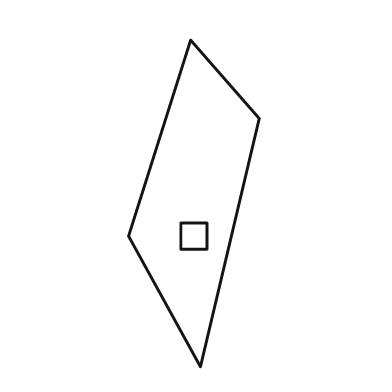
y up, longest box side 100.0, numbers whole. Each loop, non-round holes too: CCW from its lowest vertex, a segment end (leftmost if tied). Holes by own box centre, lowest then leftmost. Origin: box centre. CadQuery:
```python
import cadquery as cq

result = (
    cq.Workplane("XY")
    .moveTo(2.0, -50.0)
    .lineTo(20.0, 26.0)
    .lineTo(-1.0, 50.0)
    .lineTo(-20.0, -10.0)
    .close()
    .moveTo(-4.0, -14.0)
    .lineTo(4.0, -14.0)
    .lineTo(4.0, -6.0)
    .lineTo(-4.0, -6.0)
    .close()
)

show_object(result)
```